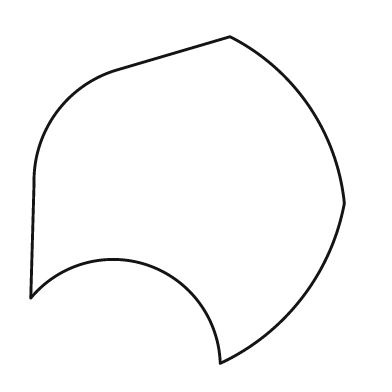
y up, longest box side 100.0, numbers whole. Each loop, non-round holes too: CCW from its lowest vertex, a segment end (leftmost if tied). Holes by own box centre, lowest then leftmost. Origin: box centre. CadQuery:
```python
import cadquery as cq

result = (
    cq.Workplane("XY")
    .moveTo(10.0, -50.0)
    .threePointArc((35.0, -30.0), (48.0, -1.0))
    .threePointArc((37.0, 29.0), (13.0, 50.0))
    .lineTo(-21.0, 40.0)
    .threePointArc((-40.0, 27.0), (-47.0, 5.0))
    .lineTo(-48.0, -30.0)
    .threePointArc((-12.0, -20.0), (10.0, -50.0))
    .close()
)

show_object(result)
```